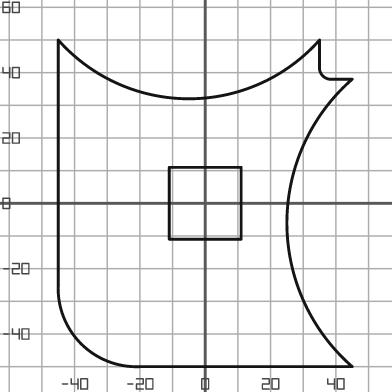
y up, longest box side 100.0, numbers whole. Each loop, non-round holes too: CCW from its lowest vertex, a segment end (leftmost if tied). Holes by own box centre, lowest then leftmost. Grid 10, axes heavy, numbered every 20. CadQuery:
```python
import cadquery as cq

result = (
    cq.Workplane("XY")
    .moveTo(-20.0, -50.0)
    .lineTo(45.0, -50.0)
    .threePointArc((25.0, -6.0), (45.0, 38.0))
    .lineTo(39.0, 38.0)
    .threePointArc((36.0, 39.0), (35.0, 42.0))
    .lineTo(35.0, 50.0)
    .threePointArc((-5.0, 32.0), (-45.0, 50.0))
    .lineTo(-45.0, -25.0)
    .threePointArc((-38.0, -43.0), (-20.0, -50.0))
    .close()
    .moveTo(-11.0, -11.0)
    .lineTo(11.0, -11.0)
    .lineTo(11.0, 11.0)
    .lineTo(-11.0, 11.0)
    .close()
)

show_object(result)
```